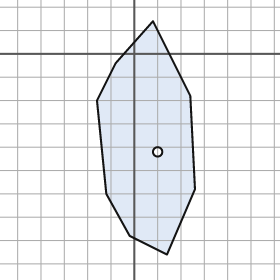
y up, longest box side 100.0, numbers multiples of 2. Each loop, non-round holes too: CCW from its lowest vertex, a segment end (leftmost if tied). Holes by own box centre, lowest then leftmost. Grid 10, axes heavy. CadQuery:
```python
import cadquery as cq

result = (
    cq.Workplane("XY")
    .moveTo(14.0, -86.0)
    .lineTo(26.0, -58.0)
    .lineTo(24.0, -18.0)
    .lineTo(8.0, 14.0)
    .lineTo(-8.0, -4.0)
    .lineTo(-16.0, -20.0)
    .lineTo(-12.0, -60.0)
    .lineTo(-2.0, -78.0)
    .close()
    .moveTo(10.0, -42.0)
    .circle(2.0)
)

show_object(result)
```